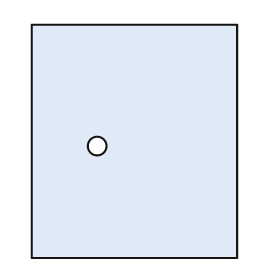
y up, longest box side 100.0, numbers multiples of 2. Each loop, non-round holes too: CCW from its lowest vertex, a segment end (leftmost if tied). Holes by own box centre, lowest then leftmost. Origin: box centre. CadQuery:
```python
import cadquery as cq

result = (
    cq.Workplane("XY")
    .moveTo(-44.0, -50.0)
    .lineTo(44.0, -50.0)
    .lineTo(44.0, 50.0)
    .lineTo(-44.0, 50.0)
    .close()
    .moveTo(-16.0, -2.0)
    .circle(4.0)
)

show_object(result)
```